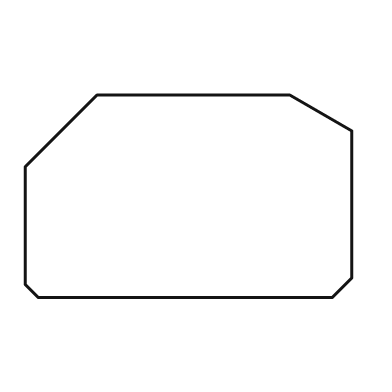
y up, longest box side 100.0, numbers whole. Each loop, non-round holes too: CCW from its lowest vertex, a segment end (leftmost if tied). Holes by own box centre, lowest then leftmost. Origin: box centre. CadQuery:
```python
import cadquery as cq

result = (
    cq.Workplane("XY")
    .moveTo(-46.0, -31.0)
    .lineTo(44.0, -31.0)
    .lineTo(50.0, -25.0)
    .lineTo(50.0, 20.0)
    .lineTo(31.0, 31.0)
    .lineTo(-28.0, 31.0)
    .lineTo(-50.0, 9.0)
    .lineTo(-50.0, -27.0)
    .close()
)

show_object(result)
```